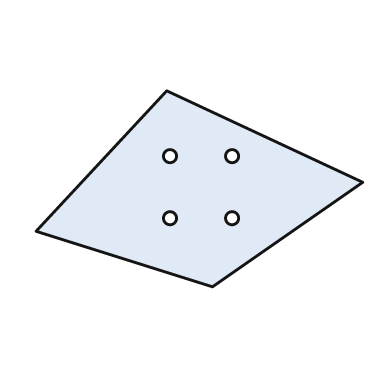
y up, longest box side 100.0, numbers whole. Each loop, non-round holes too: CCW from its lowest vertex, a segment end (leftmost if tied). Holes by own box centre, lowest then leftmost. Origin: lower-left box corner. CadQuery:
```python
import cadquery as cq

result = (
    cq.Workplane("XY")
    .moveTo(54.0, 0.0)
    .lineTo(100.0, 32.0)
    .lineTo(40.0, 60.0)
    .lineTo(0.0, 17.0)
    .close()
    .moveTo(41.0, 21.0)
    .circle(2.0)
    .moveTo(60.0, 21.0)
    .circle(2.0)
    .moveTo(41.0, 40.0)
    .circle(2.0)
    .moveTo(60.0, 40.0)
    .circle(2.0)
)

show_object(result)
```